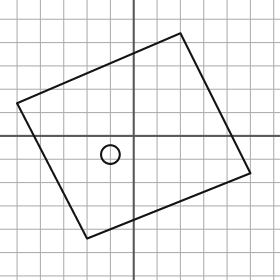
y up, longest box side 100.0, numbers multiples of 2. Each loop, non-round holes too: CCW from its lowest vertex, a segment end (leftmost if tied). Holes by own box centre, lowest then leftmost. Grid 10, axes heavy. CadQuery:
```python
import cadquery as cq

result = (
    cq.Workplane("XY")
    .moveTo(-20.0, -44.0)
    .lineTo(50.0, -16.0)
    .lineTo(20.0, 44.0)
    .lineTo(-50.0, 14.0)
    .close()
    .moveTo(-10.0, -8.0)
    .circle(4.0)
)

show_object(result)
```